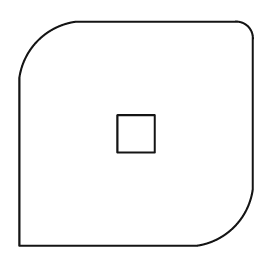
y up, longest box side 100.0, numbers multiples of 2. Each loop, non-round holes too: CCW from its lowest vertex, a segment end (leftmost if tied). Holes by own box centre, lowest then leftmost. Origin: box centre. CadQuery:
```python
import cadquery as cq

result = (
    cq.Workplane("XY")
    .moveTo(-50.0, -48.0)
    .lineTo(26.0, -48.0)
    .threePointArc((42.0, -40.0), (50.0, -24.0))
    .lineTo(50.0, 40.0)
    .threePointArc((48.0, 46.0), (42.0, 48.0))
    .lineTo(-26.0, 48.0)
    .threePointArc((-42.0, 40.0), (-50.0, 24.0))
    .close()
    .moveTo(-8.0, -8.0)
    .lineTo(8.0, -8.0)
    .lineTo(8.0, 8.0)
    .lineTo(-8.0, 8.0)
    .close()
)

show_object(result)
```